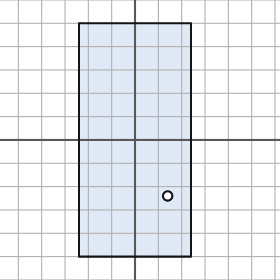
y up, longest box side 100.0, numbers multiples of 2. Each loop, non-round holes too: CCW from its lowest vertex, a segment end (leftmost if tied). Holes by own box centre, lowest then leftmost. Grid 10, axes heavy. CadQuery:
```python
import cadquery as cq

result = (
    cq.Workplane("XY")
    .moveTo(-24.0, -50.0)
    .lineTo(24.0, -50.0)
    .lineTo(24.0, 50.0)
    .lineTo(-24.0, 50.0)
    .close()
    .moveTo(14.0, -24.0)
    .circle(2.0)
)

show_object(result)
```